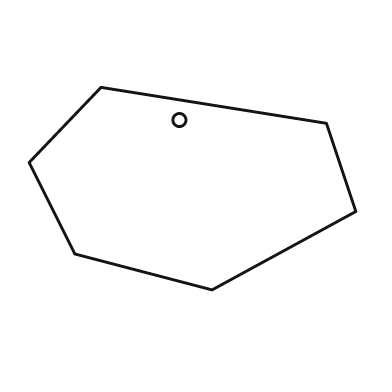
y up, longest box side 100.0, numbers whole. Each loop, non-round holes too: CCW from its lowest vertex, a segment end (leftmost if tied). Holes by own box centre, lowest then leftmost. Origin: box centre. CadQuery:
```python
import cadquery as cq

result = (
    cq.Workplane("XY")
    .moveTo(6.0, -31.0)
    .lineTo(50.0, -7.0)
    .lineTo(41.0, 20.0)
    .lineTo(-28.0, 31.0)
    .lineTo(-50.0, 8.0)
    .lineTo(-36.0, -20.0)
    .close()
    .moveTo(-4.0, 21.0)
    .circle(2.0)
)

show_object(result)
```